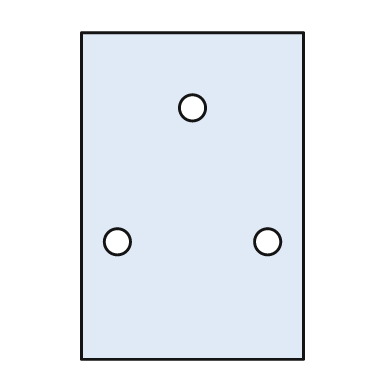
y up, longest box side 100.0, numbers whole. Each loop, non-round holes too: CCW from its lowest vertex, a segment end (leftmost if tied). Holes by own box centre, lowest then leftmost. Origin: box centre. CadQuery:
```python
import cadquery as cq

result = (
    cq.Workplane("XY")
    .moveTo(-34.0, -50.0)
    .lineTo(34.0, -50.0)
    .lineTo(34.0, 50.0)
    .lineTo(-34.0, 50.0)
    .close()
    .moveTo(-23.0, -14.0)
    .circle(4.0)
    .moveTo(23.0, -14.0)
    .circle(4.0)
    .moveTo(0.0, 27.0)
    .circle(4.0)
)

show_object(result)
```